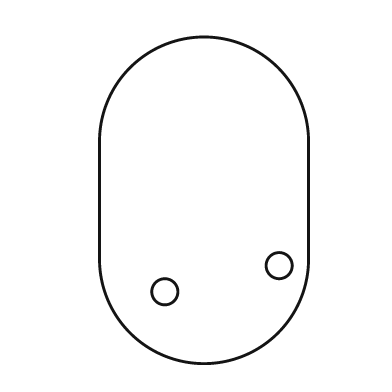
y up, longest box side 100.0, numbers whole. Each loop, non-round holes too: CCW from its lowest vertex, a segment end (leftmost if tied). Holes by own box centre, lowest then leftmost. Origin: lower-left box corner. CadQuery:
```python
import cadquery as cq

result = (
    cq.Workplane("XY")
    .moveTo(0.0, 32.0)
    .threePointArc((32.0, 0.0), (64.0, 32.0))
    .lineTo(64.0, 68.0)
    .threePointArc((32.0, 100.0), (0.0, 68.0))
    .close()
    .moveTo(20.0, 22.0)
    .circle(4.0)
    .moveTo(55.0, 30.0)
    .circle(4.0)
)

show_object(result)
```